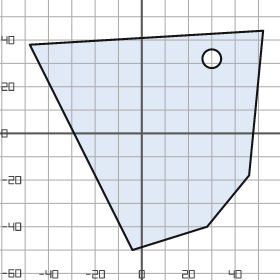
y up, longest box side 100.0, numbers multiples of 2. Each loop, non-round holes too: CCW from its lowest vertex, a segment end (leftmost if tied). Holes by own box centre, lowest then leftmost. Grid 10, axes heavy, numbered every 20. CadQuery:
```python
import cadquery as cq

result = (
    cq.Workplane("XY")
    .moveTo(-4.0, -50.0)
    .lineTo(28.0, -40.0)
    .lineTo(46.0, -18.0)
    .lineTo(52.0, 44.0)
    .lineTo(-48.0, 38.0)
    .close()
    .moveTo(30.0, 32.0)
    .circle(4.0)
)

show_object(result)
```